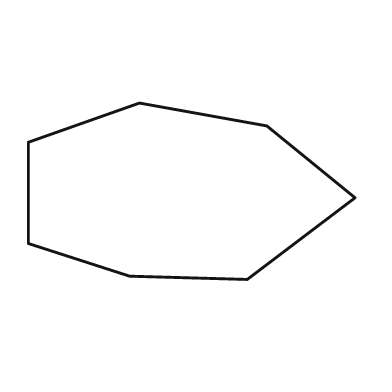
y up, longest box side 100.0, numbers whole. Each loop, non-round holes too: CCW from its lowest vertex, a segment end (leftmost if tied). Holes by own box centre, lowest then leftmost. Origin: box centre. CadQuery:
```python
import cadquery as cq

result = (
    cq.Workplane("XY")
    .moveTo(17.0, -27.0)
    .lineTo(50.0, -2.0)
    .lineTo(23.0, 20.0)
    .lineTo(-16.0, 27.0)
    .lineTo(-50.0, 15.0)
    .lineTo(-50.0, -16.0)
    .lineTo(-19.0, -26.0)
    .close()
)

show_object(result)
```